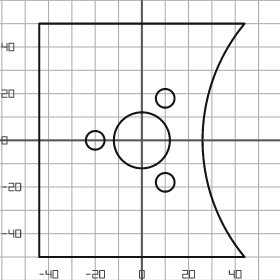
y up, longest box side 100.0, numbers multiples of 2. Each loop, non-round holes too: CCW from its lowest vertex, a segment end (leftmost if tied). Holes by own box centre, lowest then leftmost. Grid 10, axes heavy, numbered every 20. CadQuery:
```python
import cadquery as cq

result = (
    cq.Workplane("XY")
    .moveTo(-44.0, -50.0)
    .lineTo(44.0, -50.0)
    .threePointArc((26.0, 0.0), (44.0, 50.0))
    .lineTo(-44.0, 50.0)
    .close()
    .moveTo(10.0, -18.0)
    .circle(4.0)
    .moveTo(-20.0, 0.0)
    .circle(4.0)
    .moveTo(0.0, 0.0)
    .circle(12.0)
    .moveTo(10.0, 18.0)
    .circle(4.0)
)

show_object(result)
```